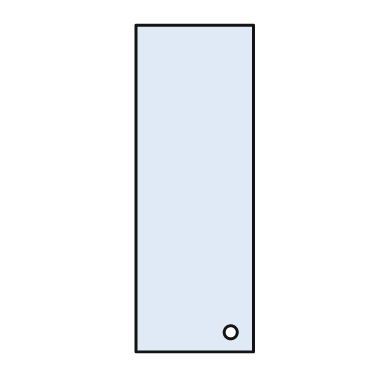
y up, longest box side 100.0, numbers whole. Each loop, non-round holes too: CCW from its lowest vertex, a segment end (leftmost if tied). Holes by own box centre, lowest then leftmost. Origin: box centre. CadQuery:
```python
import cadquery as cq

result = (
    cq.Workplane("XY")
    .moveTo(-18.0, -50.0)
    .lineTo(18.0, -50.0)
    .lineTo(18.0, 50.0)
    .lineTo(-18.0, 50.0)
    .close()
    .moveTo(11.0, -44.0)
    .circle(2.0)
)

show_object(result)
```